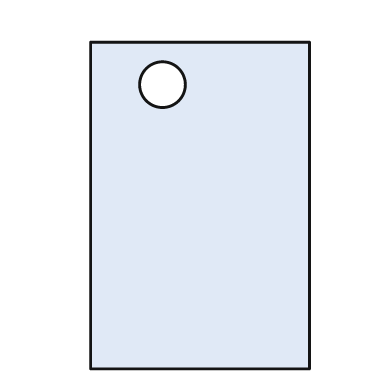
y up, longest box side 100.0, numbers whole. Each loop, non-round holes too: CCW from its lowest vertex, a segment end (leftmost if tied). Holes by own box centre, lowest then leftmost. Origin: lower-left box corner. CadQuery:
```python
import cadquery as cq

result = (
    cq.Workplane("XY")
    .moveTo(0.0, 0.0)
    .lineTo(67.0, 0.0)
    .lineTo(67.0, 100.0)
    .lineTo(0.0, 100.0)
    .close()
    .moveTo(22.0, 87.0)
    .circle(7.0)
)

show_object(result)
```